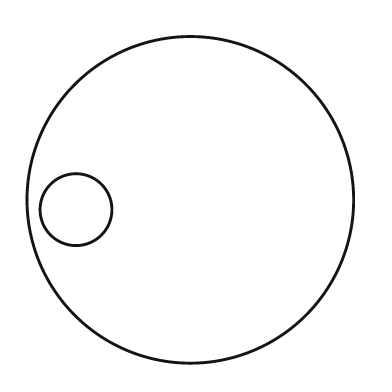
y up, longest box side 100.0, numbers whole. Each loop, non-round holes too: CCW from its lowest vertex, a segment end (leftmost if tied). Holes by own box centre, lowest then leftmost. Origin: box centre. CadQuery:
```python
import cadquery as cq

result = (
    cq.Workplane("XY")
    .moveTo(0.0, 0.0)
    .circle(50.0)
    .moveTo(-35.0, -3.0)
    .circle(11.0)
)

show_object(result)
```